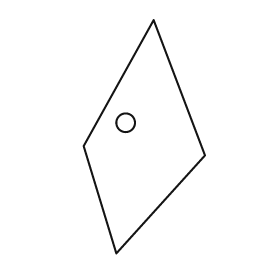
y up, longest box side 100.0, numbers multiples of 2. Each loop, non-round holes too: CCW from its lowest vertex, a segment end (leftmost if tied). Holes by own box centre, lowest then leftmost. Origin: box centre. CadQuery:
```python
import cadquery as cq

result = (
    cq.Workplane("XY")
    .moveTo(-12.0, -50.0)
    .lineTo(26.0, -8.0)
    .lineTo(4.0, 50.0)
    .lineTo(-26.0, -4.0)
    .close()
    .moveTo(-8.0, 6.0)
    .circle(4.0)
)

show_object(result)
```